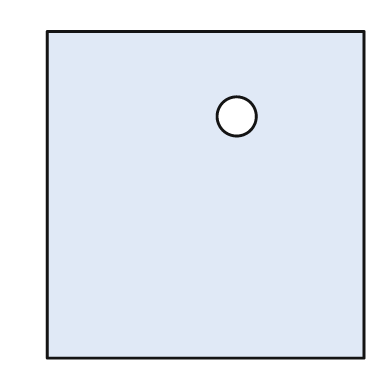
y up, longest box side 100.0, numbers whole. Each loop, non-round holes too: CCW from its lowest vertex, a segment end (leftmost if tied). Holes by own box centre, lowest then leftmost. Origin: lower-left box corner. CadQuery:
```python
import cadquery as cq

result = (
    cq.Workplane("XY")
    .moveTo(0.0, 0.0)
    .lineTo(97.0, 0.0)
    .lineTo(97.0, 100.0)
    .lineTo(0.0, 100.0)
    .close()
    .moveTo(58.0, 74.0)
    .circle(6.0)
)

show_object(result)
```